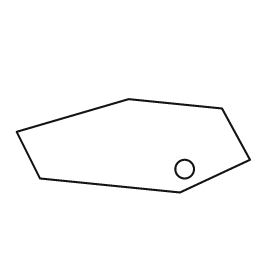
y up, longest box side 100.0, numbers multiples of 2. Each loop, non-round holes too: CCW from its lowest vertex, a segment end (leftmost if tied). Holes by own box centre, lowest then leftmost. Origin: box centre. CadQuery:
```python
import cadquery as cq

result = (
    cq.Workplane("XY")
    .moveTo(20.0, -20.0)
    .lineTo(50.0, -6.0)
    .lineTo(38.0, 16.0)
    .lineTo(-2.0, 20.0)
    .lineTo(-50.0, 6.0)
    .lineTo(-40.0, -14.0)
    .close()
    .moveTo(22.0, -10.0)
    .circle(4.0)
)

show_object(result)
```